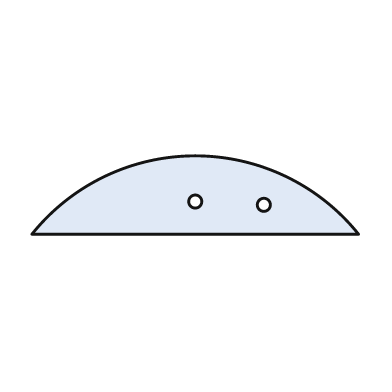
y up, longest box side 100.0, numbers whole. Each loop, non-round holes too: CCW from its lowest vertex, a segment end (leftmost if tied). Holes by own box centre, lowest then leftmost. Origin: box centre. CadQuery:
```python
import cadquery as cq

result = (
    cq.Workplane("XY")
    .moveTo(-50.0, -12.0)
    .lineTo(50.0, -12.0)
    .threePointArc((0.0, 12.0), (-50.0, -12.0))
    .close()
    .moveTo(21.0, -3.0)
    .circle(2.0)
    .moveTo(0.0, -2.0)
    .circle(2.0)
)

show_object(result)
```